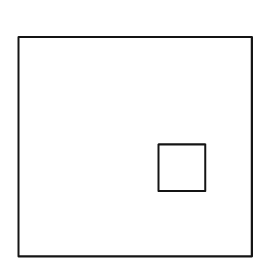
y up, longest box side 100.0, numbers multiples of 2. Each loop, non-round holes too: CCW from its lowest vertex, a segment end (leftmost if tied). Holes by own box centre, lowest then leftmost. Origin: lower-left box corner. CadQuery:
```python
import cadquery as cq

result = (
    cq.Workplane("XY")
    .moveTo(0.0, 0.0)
    .lineTo(100.0, 0.0)
    .lineTo(100.0, 94.0)
    .lineTo(0.0, 94.0)
    .close()
    .moveTo(60.0, 28.0)
    .lineTo(80.0, 28.0)
    .lineTo(80.0, 48.0)
    .lineTo(60.0, 48.0)
    .close()
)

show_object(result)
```